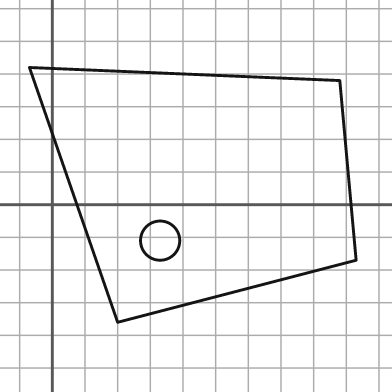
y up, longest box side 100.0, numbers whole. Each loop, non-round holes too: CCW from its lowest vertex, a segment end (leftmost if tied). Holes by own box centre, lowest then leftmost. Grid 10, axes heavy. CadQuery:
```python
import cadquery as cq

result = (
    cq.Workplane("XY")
    .moveTo(20.0, -36.0)
    .lineTo(93.0, -17.0)
    .lineTo(88.0, 38.0)
    .lineTo(-7.0, 42.0)
    .close()
    .moveTo(33.0, -11.0)
    .circle(6.0)
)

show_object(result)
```